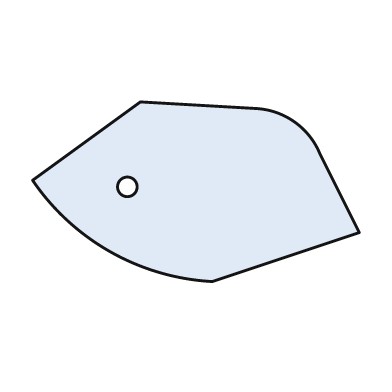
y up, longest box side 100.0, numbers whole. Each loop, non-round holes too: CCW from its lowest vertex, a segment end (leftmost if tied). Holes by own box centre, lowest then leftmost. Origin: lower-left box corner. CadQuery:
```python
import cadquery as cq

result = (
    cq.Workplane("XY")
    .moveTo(55.0, 0.0)
    .lineTo(100.0, 15.0)
    .lineTo(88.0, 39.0)
    .threePointArc((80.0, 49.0), (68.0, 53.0))
    .lineTo(33.0, 55.0)
    .lineTo(0.0, 31.0)
    .threePointArc((24.0, 9.0), (55.0, 0.0))
    .close()
    .moveTo(29.0, 29.0)
    .circle(3.0)
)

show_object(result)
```